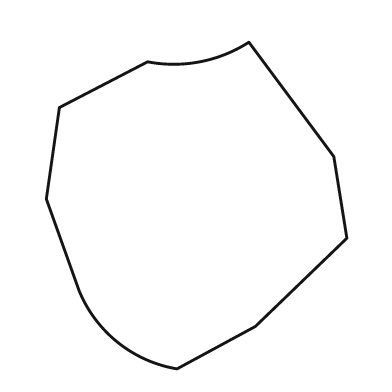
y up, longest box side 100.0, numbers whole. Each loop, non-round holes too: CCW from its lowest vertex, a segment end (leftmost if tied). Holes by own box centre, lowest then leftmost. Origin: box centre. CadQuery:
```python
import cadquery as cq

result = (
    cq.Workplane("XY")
    .moveTo(-6.0, -50.0)
    .lineTo(18.0, -37.0)
    .lineTo(46.0, -10.0)
    .lineTo(42.0, 15.0)
    .lineTo(16.0, 50.0)
    .threePointArc((1.0, 44.0), (-15.0, 44.0))
    .lineTo(-42.0, 30.0)
    .lineTo(-46.0, 2.0)
    .lineTo(-36.0, -26.0)
    .threePointArc((-24.0, -42.0), (-6.0, -50.0))
    .close()
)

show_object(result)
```